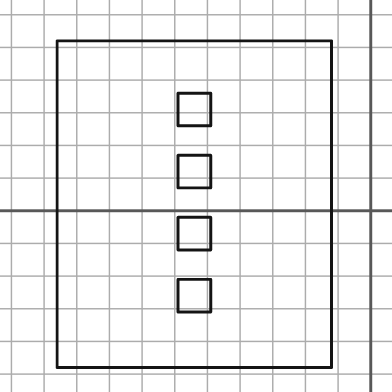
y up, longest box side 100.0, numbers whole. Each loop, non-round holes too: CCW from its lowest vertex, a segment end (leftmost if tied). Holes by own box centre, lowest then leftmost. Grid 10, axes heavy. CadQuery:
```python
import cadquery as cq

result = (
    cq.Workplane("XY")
    .moveTo(-96.0, -48.0)
    .lineTo(-12.0, -48.0)
    .lineTo(-12.0, 52.0)
    .lineTo(-96.0, 52.0)
    .close()
    .moveTo(-59.0, -31.0)
    .lineTo(-49.0, -31.0)
    .lineTo(-49.0, -21.0)
    .lineTo(-59.0, -21.0)
    .close()
    .moveTo(-59.0, -12.0)
    .lineTo(-49.0, -12.0)
    .lineTo(-49.0, -2.0)
    .lineTo(-59.0, -2.0)
    .close()
    .moveTo(-59.0, 7.0)
    .lineTo(-49.0, 7.0)
    .lineTo(-49.0, 17.0)
    .lineTo(-59.0, 17.0)
    .close()
    .moveTo(-59.0, 26.0)
    .lineTo(-49.0, 26.0)
    .lineTo(-49.0, 36.0)
    .lineTo(-59.0, 36.0)
    .close()
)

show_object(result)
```